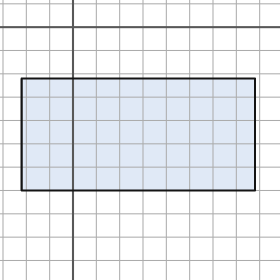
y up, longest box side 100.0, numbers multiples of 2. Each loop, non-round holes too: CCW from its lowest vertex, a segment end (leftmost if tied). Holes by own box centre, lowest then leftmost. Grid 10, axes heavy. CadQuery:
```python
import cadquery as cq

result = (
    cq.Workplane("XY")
    .moveTo(-22.0, -70.0)
    .lineTo(78.0, -70.0)
    .lineTo(78.0, -22.0)
    .lineTo(-22.0, -22.0)
    .close()
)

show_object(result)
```